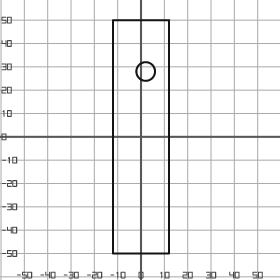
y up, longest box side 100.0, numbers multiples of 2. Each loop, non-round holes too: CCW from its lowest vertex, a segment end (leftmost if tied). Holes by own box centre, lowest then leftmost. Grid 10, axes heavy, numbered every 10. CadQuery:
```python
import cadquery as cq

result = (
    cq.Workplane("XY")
    .moveTo(-12.0, -50.0)
    .lineTo(12.0, -50.0)
    .lineTo(12.0, 50.0)
    .lineTo(-12.0, 50.0)
    .close()
    .moveTo(2.0, 28.0)
    .circle(4.0)
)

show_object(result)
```